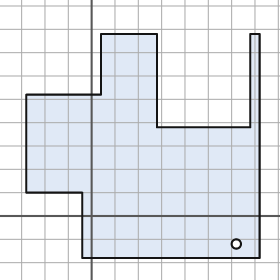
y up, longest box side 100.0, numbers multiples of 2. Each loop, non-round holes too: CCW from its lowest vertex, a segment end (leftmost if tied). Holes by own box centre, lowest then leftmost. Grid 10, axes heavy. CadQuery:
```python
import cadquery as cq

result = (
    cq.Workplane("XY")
    .moveTo(-4.0, -18.0)
    .lineTo(72.0, -18.0)
    .lineTo(72.0, 78.0)
    .lineTo(68.0, 78.0)
    .lineTo(68.0, 38.0)
    .lineTo(28.0, 38.0)
    .lineTo(28.0, 78.0)
    .lineTo(4.0, 78.0)
    .lineTo(4.0, 52.0)
    .lineTo(-28.0, 52.0)
    .lineTo(-28.0, 10.0)
    .lineTo(-4.0, 10.0)
    .close()
    .moveTo(62.0, -12.0)
    .circle(2.0)
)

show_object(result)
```